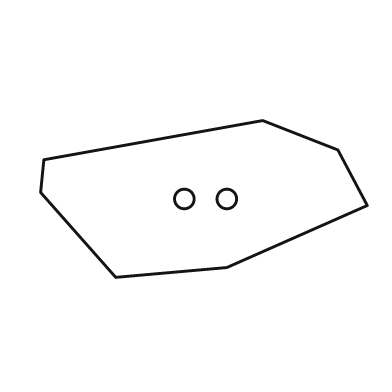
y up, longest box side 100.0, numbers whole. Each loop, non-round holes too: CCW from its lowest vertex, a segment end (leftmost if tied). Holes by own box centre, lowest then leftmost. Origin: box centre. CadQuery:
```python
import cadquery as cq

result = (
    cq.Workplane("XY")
    .moveTo(-27.0, -24.0)
    .lineTo(7.0, -21.0)
    .lineTo(50.0, -2.0)
    .lineTo(41.0, 15.0)
    .lineTo(18.0, 24.0)
    .lineTo(-49.0, 12.0)
    .lineTo(-50.0, 2.0)
    .close()
    .moveTo(-6.0, 0.0)
    .circle(3.0)
    .moveTo(7.0, 0.0)
    .circle(3.0)
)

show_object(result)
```